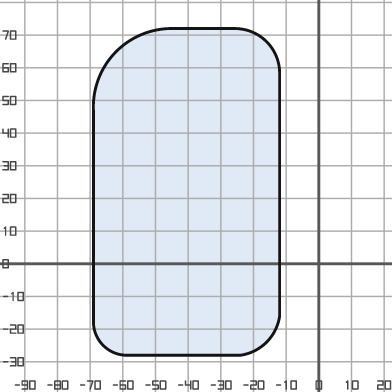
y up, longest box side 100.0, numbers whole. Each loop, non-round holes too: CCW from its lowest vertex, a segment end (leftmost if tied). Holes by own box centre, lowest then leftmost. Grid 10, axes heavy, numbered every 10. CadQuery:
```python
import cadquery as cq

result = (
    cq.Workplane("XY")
    .moveTo(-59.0, -28.0)
    .lineTo(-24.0, -28.0)
    .threePointArc((-16.0, -24.0), (-12.0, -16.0))
    .lineTo(-12.0, 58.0)
    .threePointArc((-16.0, 68.0), (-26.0, 72.0))
    .lineTo(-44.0, 72.0)
    .threePointArc((-62.0, 65.0), (-69.0, 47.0))
    .lineTo(-69.0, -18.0)
    .threePointArc((-66.0, -25.0), (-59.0, -28.0))
    .close()
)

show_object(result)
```